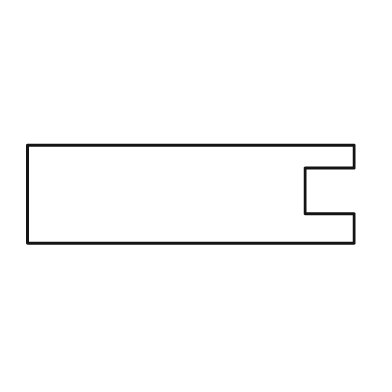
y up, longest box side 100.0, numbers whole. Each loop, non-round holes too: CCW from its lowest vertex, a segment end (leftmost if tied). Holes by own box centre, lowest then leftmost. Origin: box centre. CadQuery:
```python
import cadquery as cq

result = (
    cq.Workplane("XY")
    .moveTo(-50.0, -15.0)
    .lineTo(50.0, -15.0)
    .lineTo(50.0, -6.0)
    .lineTo(35.0, -6.0)
    .lineTo(35.0, 8.0)
    .lineTo(50.0, 8.0)
    .lineTo(50.0, 15.0)
    .lineTo(-50.0, 15.0)
    .close()
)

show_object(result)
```